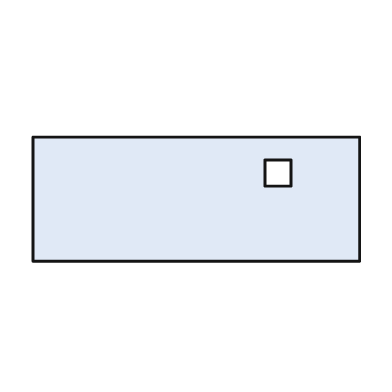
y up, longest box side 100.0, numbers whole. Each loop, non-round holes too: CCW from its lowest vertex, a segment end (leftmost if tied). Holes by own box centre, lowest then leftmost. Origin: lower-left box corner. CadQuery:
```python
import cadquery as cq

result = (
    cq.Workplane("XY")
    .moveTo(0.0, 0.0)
    .lineTo(100.0, 0.0)
    .lineTo(100.0, 38.0)
    .lineTo(0.0, 38.0)
    .close()
    .moveTo(71.0, 23.0)
    .lineTo(79.0, 23.0)
    .lineTo(79.0, 31.0)
    .lineTo(71.0, 31.0)
    .close()
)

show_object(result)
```